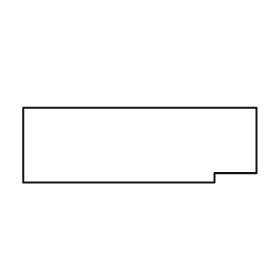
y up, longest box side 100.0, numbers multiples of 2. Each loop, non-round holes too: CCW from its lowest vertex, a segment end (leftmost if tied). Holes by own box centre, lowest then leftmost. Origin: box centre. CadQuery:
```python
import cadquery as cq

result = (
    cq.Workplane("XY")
    .moveTo(-50.0, -16.0)
    .lineTo(32.0, -16.0)
    .lineTo(32.0, -12.0)
    .lineTo(50.0, -12.0)
    .lineTo(50.0, 16.0)
    .lineTo(-50.0, 16.0)
    .close()
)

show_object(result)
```